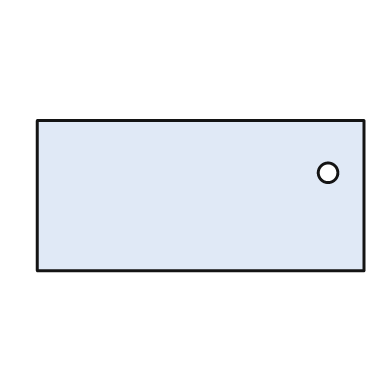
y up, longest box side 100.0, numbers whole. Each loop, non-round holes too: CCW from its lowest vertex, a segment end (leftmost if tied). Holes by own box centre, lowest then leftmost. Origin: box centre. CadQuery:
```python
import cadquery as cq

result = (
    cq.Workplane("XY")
    .moveTo(-50.0, -23.0)
    .lineTo(50.0, -23.0)
    .lineTo(50.0, 23.0)
    .lineTo(-50.0, 23.0)
    .close()
    .moveTo(39.0, 7.0)
    .circle(3.0)
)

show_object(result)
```